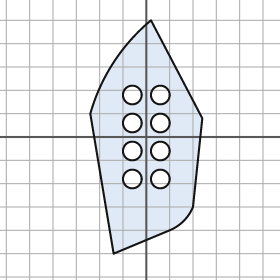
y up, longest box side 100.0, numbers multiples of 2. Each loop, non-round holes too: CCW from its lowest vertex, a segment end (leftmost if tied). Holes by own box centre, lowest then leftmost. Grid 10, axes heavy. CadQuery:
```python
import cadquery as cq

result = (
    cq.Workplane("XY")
    .moveTo(-14.0, -50.0)
    .lineTo(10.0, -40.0)
    .threePointArc((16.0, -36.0), (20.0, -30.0))
    .lineTo(24.0, 8.0)
    .lineTo(2.0, 50.0)
    .threePointArc((-14.0, 32.0), (-24.0, 10.0))
    .close()
    .moveTo(-6.0, -18.0)
    .circle(4.0)
    .moveTo(6.0, -18.0)
    .circle(4.0)
    .moveTo(-6.0, -6.0)
    .circle(4.0)
    .moveTo(6.0, -6.0)
    .circle(4.0)
    .moveTo(-6.0, 6.0)
    .circle(4.0)
    .moveTo(6.0, 6.0)
    .circle(4.0)
    .moveTo(-6.0, 18.0)
    .circle(4.0)
    .moveTo(6.0, 18.0)
    .circle(4.0)
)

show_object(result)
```